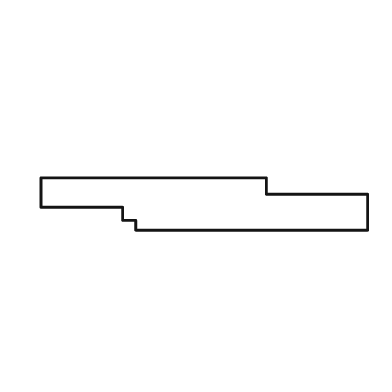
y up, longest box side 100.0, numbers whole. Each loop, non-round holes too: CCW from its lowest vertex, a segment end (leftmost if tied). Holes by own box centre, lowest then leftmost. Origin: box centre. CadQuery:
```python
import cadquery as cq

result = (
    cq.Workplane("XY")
    .moveTo(-21.0, -8.0)
    .lineTo(50.0, -8.0)
    .lineTo(50.0, 3.0)
    .lineTo(19.0, 3.0)
    .lineTo(19.0, 8.0)
    .lineTo(-50.0, 8.0)
    .lineTo(-50.0, -1.0)
    .lineTo(-25.0, -1.0)
    .lineTo(-25.0, -5.0)
    .lineTo(-21.0, -5.0)
    .close()
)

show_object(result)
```